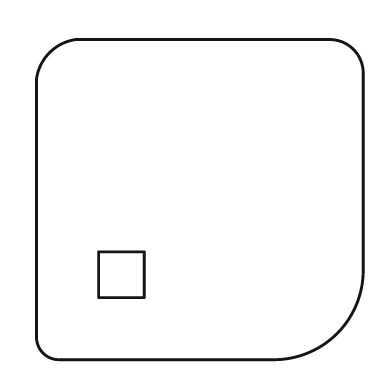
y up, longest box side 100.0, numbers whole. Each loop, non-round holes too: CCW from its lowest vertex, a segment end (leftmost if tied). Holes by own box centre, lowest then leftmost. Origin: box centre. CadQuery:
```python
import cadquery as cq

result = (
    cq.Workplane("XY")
    .moveTo(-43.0, -49.0)
    .lineTo(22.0, -49.0)
    .threePointArc((42.0, -41.0), (50.0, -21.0))
    .lineTo(50.0, 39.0)
    .threePointArc((47.0, 46.0), (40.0, 49.0))
    .lineTo(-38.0, 49.0)
    .threePointArc((-46.0, 45.0), (-50.0, 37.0))
    .lineTo(-50.0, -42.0)
    .threePointArc((-48.0, -47.0), (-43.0, -49.0))
    .close()
    .moveTo(-31.0, -30.0)
    .lineTo(-17.0, -30.0)
    .lineTo(-17.0, -16.0)
    .lineTo(-31.0, -16.0)
    .close()
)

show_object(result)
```